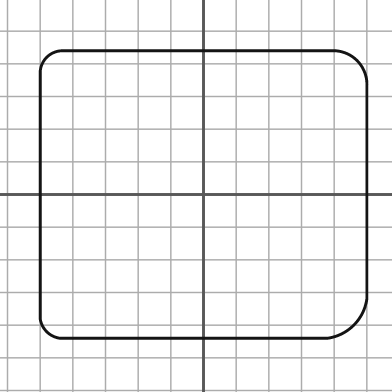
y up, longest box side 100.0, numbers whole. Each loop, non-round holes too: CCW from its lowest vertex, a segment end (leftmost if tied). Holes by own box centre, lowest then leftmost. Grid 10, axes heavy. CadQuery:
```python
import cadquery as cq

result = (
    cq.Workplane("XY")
    .moveTo(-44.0, -44.0)
    .lineTo(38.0, -44.0)
    .threePointArc((46.0, -40.0), (50.0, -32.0))
    .lineTo(50.0, 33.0)
    .threePointArc((47.0, 41.0), (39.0, 44.0))
    .lineTo(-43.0, 44.0)
    .threePointArc((-48.0, 42.0), (-50.0, 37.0))
    .lineTo(-50.0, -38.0)
    .threePointArc((-48.0, -42.0), (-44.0, -44.0))
    .close()
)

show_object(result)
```